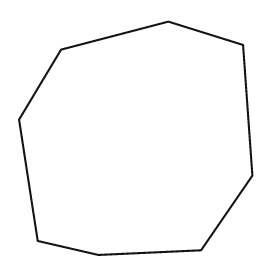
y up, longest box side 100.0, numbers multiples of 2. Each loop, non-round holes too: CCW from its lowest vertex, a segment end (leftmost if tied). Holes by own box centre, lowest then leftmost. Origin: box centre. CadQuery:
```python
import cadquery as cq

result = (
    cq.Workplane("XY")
    .moveTo(-16.0, -50.0)
    .lineTo(28.0, -48.0)
    .lineTo(50.0, -16.0)
    .lineTo(46.0, 40.0)
    .lineTo(14.0, 50.0)
    .lineTo(-32.0, 38.0)
    .lineTo(-50.0, 8.0)
    .lineTo(-42.0, -44.0)
    .close()
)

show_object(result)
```